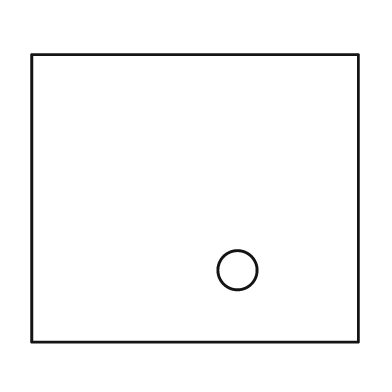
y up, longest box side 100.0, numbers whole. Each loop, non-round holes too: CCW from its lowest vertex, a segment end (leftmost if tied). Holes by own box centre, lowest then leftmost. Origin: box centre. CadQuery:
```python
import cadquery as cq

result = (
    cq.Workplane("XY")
    .moveTo(-50.0, -44.0)
    .lineTo(50.0, -44.0)
    .lineTo(50.0, 44.0)
    .lineTo(-50.0, 44.0)
    .close()
    .moveTo(13.0, -22.0)
    .circle(6.0)
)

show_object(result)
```